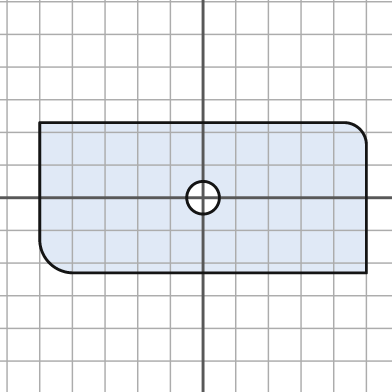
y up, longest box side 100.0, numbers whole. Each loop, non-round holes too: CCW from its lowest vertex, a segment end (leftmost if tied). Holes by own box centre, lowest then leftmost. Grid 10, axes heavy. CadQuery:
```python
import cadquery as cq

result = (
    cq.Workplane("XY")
    .moveTo(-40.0, -23.0)
    .lineTo(50.0, -23.0)
    .lineTo(50.0, 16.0)
    .threePointArc((48.0, 21.0), (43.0, 23.0))
    .lineTo(-50.0, 23.0)
    .lineTo(-50.0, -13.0)
    .threePointArc((-47.0, -20.0), (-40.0, -23.0))
    .close()
    .moveTo(0.0, 0.0)
    .circle(5.0)
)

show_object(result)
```